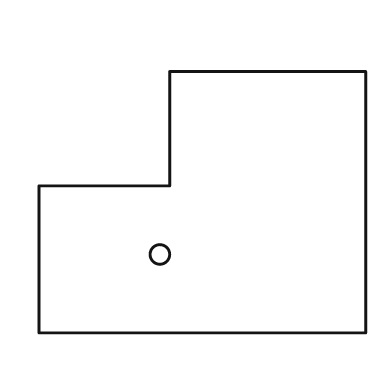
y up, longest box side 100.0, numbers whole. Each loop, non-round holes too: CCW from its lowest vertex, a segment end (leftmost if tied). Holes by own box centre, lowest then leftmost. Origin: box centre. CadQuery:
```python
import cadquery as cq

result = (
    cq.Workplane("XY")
    .moveTo(-50.0, -40.0)
    .lineTo(50.0, -40.0)
    .lineTo(50.0, 40.0)
    .lineTo(-10.0, 40.0)
    .lineTo(-10.0, 5.0)
    .lineTo(-50.0, 5.0)
    .close()
    .moveTo(-13.0, -16.0)
    .circle(3.0)
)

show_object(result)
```